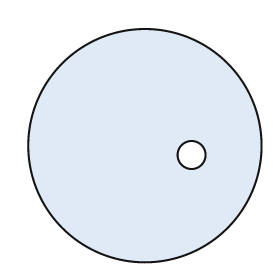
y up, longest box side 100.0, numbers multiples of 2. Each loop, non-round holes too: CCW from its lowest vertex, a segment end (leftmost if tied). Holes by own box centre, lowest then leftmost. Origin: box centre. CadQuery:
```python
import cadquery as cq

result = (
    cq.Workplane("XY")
    .moveTo(0.0, 0.0)
    .circle(50.0)
    .moveTo(20.0, -4.0)
    .circle(6.0)
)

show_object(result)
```